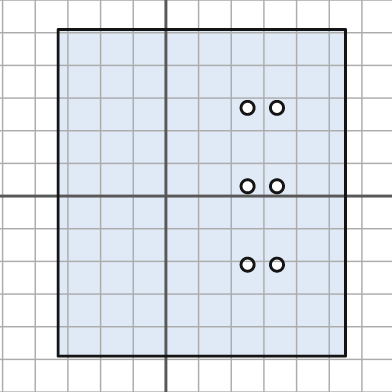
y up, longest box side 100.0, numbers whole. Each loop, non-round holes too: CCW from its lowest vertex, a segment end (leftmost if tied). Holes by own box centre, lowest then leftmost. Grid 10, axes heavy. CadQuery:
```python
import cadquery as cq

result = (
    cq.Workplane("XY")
    .moveTo(-33.0, -49.0)
    .lineTo(55.0, -49.0)
    .lineTo(55.0, 51.0)
    .lineTo(-33.0, 51.0)
    .close()
    .moveTo(25.0, -21.0)
    .circle(2.0)
    .moveTo(34.0, -21.0)
    .circle(2.0)
    .moveTo(25.0, 3.0)
    .circle(2.0)
    .moveTo(34.0, 3.0)
    .circle(2.0)
    .moveTo(25.0, 27.0)
    .circle(2.0)
    .moveTo(34.0, 27.0)
    .circle(2.0)
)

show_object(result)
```